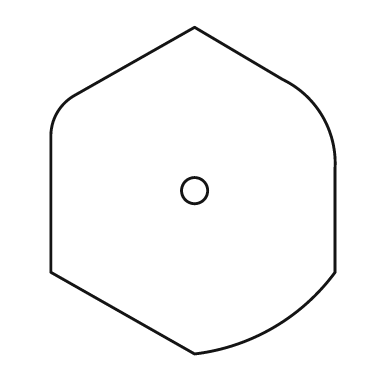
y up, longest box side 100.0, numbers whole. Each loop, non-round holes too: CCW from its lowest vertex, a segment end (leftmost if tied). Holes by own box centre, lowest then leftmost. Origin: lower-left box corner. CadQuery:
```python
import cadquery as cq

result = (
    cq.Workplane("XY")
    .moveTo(44.0, 0.0)
    .threePointArc((68.0, 8.0), (87.0, 25.0))
    .lineTo(87.0, 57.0)
    .threePointArc((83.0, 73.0), (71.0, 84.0))
    .lineTo(44.0, 100.0)
    .lineTo(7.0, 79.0)
    .threePointArc((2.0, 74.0), (0.0, 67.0))
    .lineTo(0.0, 25.0)
    .close()
    .moveTo(44.0, 50.0)
    .circle(4.0)
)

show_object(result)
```